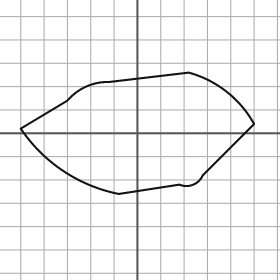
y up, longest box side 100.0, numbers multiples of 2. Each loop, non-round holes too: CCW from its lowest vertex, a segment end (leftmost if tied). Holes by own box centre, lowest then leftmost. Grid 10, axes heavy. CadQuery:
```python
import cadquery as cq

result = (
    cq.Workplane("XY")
    .moveTo(-8.0, -26.0)
    .lineTo(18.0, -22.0)
    .threePointArc((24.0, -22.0), (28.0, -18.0))
    .lineTo(50.0, 4.0)
    .threePointArc((38.0, 18.0), (22.0, 26.0))
    .lineTo(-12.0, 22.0)
    .threePointArc((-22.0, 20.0), (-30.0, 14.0))
    .lineTo(-50.0, 2.0)
    .threePointArc((-32.0, -16.0), (-8.0, -26.0))
    .close()
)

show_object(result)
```